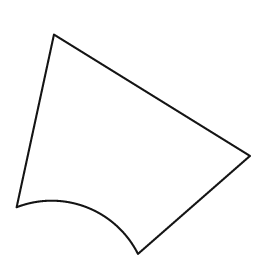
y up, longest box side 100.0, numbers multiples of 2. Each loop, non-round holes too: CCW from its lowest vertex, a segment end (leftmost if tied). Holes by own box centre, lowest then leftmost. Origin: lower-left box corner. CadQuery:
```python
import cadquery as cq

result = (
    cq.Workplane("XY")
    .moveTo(52.0, 0.0)
    .lineTo(100.0, 42.0)
    .lineTo(16.0, 94.0)
    .lineTo(0.0, 20.0)
    .threePointArc((30.0, 20.0), (52.0, 0.0))
    .close()
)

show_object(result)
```